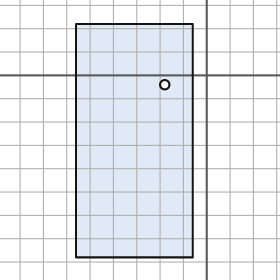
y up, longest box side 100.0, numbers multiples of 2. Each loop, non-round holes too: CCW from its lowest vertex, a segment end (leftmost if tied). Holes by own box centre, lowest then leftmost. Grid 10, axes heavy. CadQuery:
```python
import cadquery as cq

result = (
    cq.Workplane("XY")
    .moveTo(-56.0, -78.0)
    .lineTo(-6.0, -78.0)
    .lineTo(-6.0, 22.0)
    .lineTo(-56.0, 22.0)
    .close()
    .moveTo(-18.0, -4.0)
    .circle(2.0)
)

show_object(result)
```